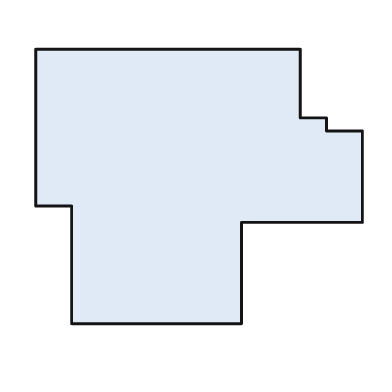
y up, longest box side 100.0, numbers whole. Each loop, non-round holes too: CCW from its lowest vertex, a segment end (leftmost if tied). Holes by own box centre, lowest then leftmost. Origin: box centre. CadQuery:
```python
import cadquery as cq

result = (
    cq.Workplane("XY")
    .moveTo(-39.0, -42.0)
    .lineTo(13.0, -42.0)
    .lineTo(13.0, -11.0)
    .lineTo(50.0, -11.0)
    .lineTo(50.0, 17.0)
    .lineTo(39.0, 17.0)
    .lineTo(39.0, 21.0)
    .lineTo(31.0, 21.0)
    .lineTo(31.0, 42.0)
    .lineTo(-50.0, 42.0)
    .lineTo(-50.0, -6.0)
    .lineTo(-39.0, -6.0)
    .close()
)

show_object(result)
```